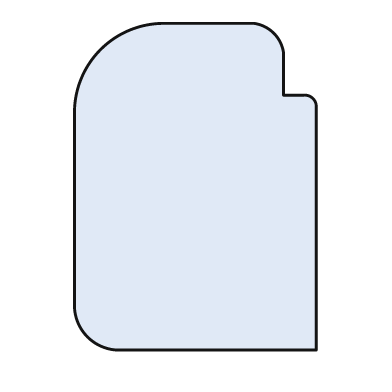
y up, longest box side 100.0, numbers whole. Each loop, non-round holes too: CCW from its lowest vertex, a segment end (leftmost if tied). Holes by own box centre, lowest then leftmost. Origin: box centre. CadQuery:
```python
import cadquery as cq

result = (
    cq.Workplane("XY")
    .moveTo(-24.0, -50.0)
    .lineTo(37.0, -50.0)
    .lineTo(37.0, 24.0)
    .threePointArc((36.0, 27.0), (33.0, 28.0))
    .lineTo(27.0, 28.0)
    .lineTo(27.0, 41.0)
    .threePointArc((24.0, 47.0), (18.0, 50.0))
    .lineTo(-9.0, 50.0)
    .threePointArc((-29.0, 42.0), (-37.0, 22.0))
    .lineTo(-37.0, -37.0)
    .threePointArc((-33.0, -46.0), (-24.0, -50.0))
    .close()
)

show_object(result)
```